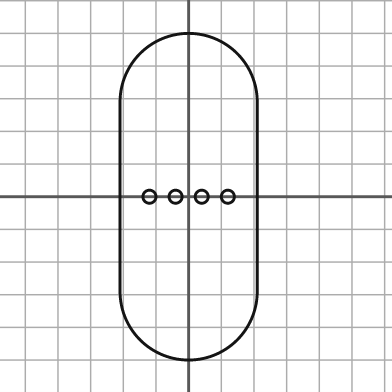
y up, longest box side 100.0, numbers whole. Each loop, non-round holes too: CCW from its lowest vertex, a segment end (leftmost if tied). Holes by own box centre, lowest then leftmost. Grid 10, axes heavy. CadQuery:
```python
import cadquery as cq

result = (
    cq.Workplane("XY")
    .moveTo(-21.0, -29.0)
    .threePointArc((0.0, -50.0), (21.0, -29.0))
    .lineTo(21.0, 29.0)
    .threePointArc((0.0, 50.0), (-21.0, 29.0))
    .close()
    .moveTo(-12.0, 0.0)
    .circle(2.0)
    .moveTo(-4.0, 0.0)
    .circle(2.0)
    .moveTo(4.0, 0.0)
    .circle(2.0)
    .moveTo(12.0, 0.0)
    .circle(2.0)
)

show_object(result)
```